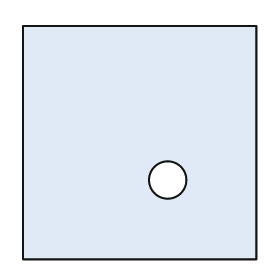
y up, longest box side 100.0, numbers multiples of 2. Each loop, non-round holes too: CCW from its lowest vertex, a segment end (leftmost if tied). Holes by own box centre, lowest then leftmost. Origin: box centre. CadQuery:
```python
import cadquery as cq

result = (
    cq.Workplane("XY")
    .moveTo(-50.0, -50.0)
    .lineTo(50.0, -50.0)
    .lineTo(50.0, 50.0)
    .lineTo(-50.0, 50.0)
    .close()
    .moveTo(12.0, -16.0)
    .circle(8.0)
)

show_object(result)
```